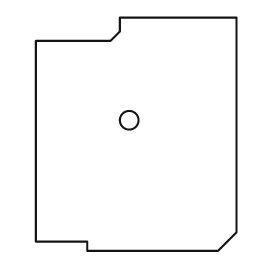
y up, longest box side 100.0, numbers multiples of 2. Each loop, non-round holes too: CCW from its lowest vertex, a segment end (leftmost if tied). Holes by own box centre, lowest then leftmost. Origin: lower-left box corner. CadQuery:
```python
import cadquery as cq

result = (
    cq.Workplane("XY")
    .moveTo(22.0, 0.0)
    .lineTo(78.0, 0.0)
    .lineTo(86.0, 8.0)
    .lineTo(86.0, 100.0)
    .lineTo(36.0, 100.0)
    .lineTo(36.0, 94.0)
    .lineTo(32.0, 90.0)
    .lineTo(0.0, 90.0)
    .lineTo(0.0, 4.0)
    .lineTo(22.0, 4.0)
    .close()
    .moveTo(40.0, 56.0)
    .circle(4.0)
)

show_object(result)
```